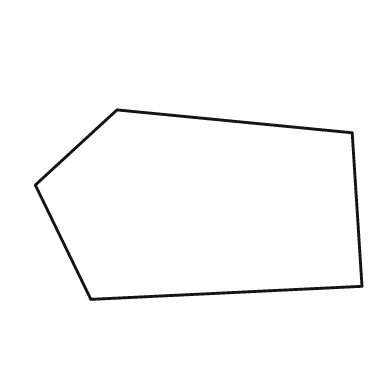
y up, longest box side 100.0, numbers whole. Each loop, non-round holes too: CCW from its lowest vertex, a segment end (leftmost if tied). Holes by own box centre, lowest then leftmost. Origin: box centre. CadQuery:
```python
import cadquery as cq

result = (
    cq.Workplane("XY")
    .moveTo(-33.0, -29.0)
    .lineTo(50.0, -25.0)
    .lineTo(47.0, 22.0)
    .lineTo(-25.0, 29.0)
    .lineTo(-50.0, 6.0)
    .close()
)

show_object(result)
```